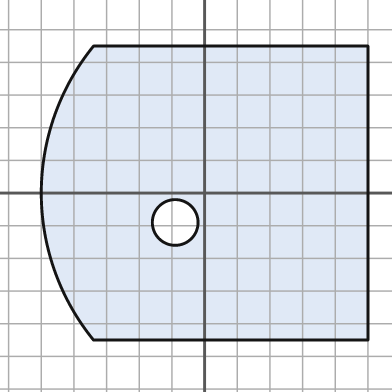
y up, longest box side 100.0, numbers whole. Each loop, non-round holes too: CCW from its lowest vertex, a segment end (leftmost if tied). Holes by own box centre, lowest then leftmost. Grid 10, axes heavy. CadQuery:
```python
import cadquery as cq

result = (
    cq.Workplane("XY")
    .moveTo(-34.0, -45.0)
    .lineTo(50.0, -45.0)
    .lineTo(50.0, 45.0)
    .lineTo(-34.0, 45.0)
    .threePointArc((-50.0, 0.0), (-34.0, -45.0))
    .close()
    .moveTo(-9.0, -9.0)
    .circle(7.0)
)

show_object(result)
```